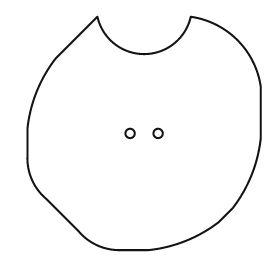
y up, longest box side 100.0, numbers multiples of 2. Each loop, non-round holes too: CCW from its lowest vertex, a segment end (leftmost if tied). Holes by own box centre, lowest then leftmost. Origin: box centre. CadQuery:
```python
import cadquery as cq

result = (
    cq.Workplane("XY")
    .moveTo(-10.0, -50.0)
    .lineTo(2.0, -50.0)
    .threePointArc((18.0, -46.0), (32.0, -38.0))
    .lineTo(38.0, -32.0)
    .threePointArc((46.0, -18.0), (50.0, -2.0))
    .lineTo(50.0, 20.0)
    .threePointArc((40.0, 40.0), (20.0, 50.0))
    .threePointArc((0.0, 34.0), (-20.0, 50.0))
    .lineTo(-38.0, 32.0)
    .threePointArc((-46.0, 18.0), (-50.0, 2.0))
    .lineTo(-50.0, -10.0)
    .threePointArc((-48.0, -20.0), (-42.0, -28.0))
    .lineTo(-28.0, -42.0)
    .threePointArc((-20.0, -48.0), (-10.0, -50.0))
    .close()
    .moveTo(-6.0, 0.0)
    .circle(2.0)
    .moveTo(6.0, 0.0)
    .circle(2.0)
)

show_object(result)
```